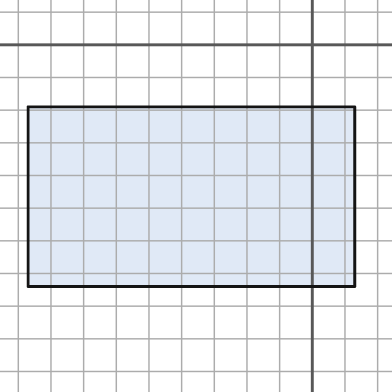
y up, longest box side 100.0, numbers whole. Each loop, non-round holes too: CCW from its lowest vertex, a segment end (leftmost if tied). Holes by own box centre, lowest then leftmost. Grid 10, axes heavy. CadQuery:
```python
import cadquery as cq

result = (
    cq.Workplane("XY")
    .moveTo(-87.0, -74.0)
    .lineTo(13.0, -74.0)
    .lineTo(13.0, -19.0)
    .lineTo(-87.0, -19.0)
    .close()
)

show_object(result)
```